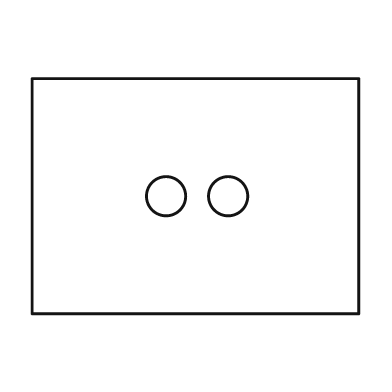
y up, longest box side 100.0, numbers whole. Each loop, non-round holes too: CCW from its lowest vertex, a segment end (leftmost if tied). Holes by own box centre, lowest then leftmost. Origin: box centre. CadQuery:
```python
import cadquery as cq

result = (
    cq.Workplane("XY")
    .moveTo(-50.0, -36.0)
    .lineTo(50.0, -36.0)
    .lineTo(50.0, 36.0)
    .lineTo(-50.0, 36.0)
    .close()
    .moveTo(-9.0, 0.0)
    .circle(6.0)
    .moveTo(10.0, 0.0)
    .circle(6.0)
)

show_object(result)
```